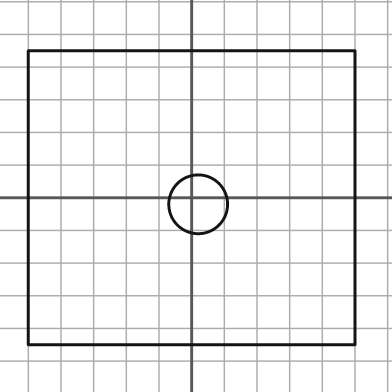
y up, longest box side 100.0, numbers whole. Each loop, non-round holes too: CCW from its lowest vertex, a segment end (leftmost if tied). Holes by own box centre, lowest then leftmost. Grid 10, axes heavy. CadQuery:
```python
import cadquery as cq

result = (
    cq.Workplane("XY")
    .moveTo(-50.0, -45.0)
    .lineTo(50.0, -45.0)
    .lineTo(50.0, 45.0)
    .lineTo(-50.0, 45.0)
    .close()
    .moveTo(2.0, -2.0)
    .circle(9.0)
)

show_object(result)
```